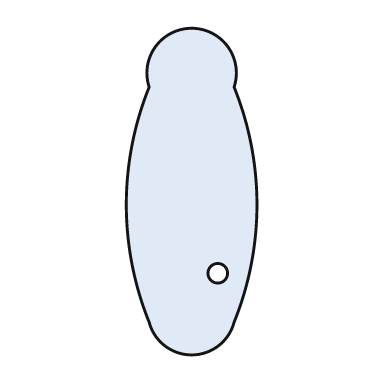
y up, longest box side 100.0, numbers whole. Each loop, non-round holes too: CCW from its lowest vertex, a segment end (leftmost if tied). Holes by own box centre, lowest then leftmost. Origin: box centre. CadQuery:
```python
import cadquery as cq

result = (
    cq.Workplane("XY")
    .moveTo(-13.0, -40.0)
    .threePointArc((0.0, -50.0), (13.0, -40.0))
    .threePointArc((20.0, -4.0), (13.0, 32.0))
    .threePointArc((0.0, 50.0), (-13.0, 32.0))
    .threePointArc((-20.0, -4.0), (-13.0, -40.0))
    .close()
    .moveTo(8.0, -25.0)
    .circle(3.0)
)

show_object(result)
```